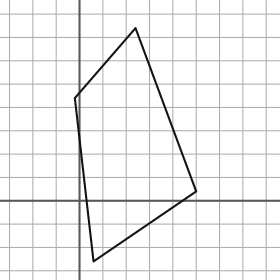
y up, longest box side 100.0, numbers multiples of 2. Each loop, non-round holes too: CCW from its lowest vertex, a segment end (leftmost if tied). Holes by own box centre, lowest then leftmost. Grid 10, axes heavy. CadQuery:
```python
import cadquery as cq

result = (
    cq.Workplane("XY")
    .moveTo(6.0, -26.0)
    .lineTo(50.0, 4.0)
    .lineTo(24.0, 74.0)
    .lineTo(-2.0, 44.0)
    .close()
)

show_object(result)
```